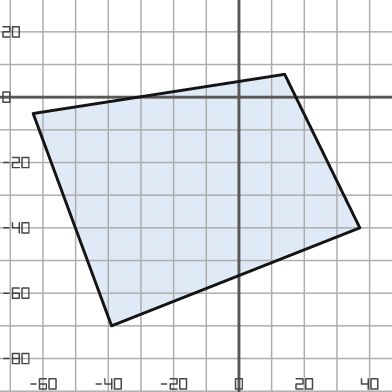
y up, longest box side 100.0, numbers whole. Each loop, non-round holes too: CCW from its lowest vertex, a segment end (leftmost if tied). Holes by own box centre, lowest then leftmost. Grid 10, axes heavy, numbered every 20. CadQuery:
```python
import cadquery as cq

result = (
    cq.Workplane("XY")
    .moveTo(-39.0, -70.0)
    .lineTo(37.0, -40.0)
    .lineTo(14.0, 7.0)
    .lineTo(-63.0, -5.0)
    .close()
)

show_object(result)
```